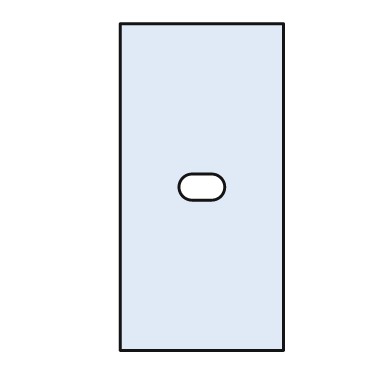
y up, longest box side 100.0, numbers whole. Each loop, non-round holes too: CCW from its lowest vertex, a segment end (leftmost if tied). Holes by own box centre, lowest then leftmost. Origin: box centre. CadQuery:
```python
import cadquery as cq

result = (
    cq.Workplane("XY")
    .moveTo(-25.0, -50.0)
    .lineTo(25.0, -50.0)
    .lineTo(25.0, 50.0)
    .lineTo(-25.0, 50.0)
    .close()
    .moveTo(-3.0, -4.0)
    .lineTo(3.0, -4.0)
    .threePointArc((7.0, 0.0), (3.0, 4.0))
    .lineTo(-3.0, 4.0)
    .threePointArc((-7.0, 0.0), (-3.0, -4.0))
    .close()
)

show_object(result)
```